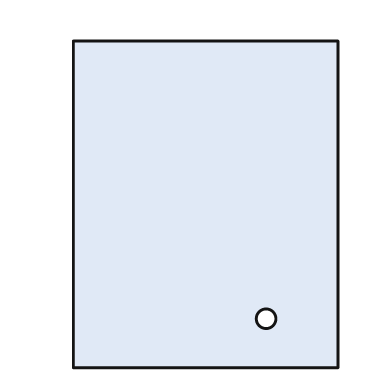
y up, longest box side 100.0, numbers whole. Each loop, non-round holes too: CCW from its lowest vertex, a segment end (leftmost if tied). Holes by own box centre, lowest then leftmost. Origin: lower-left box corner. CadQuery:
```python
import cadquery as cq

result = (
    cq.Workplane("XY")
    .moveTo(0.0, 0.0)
    .lineTo(81.0, 0.0)
    .lineTo(81.0, 100.0)
    .lineTo(0.0, 100.0)
    .close()
    .moveTo(59.0, 15.0)
    .circle(3.0)
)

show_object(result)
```